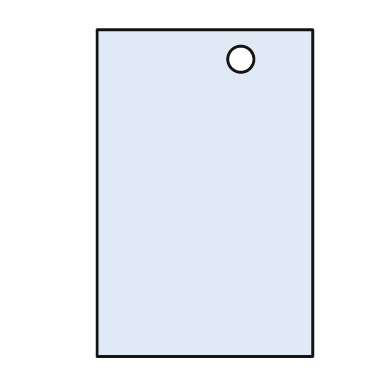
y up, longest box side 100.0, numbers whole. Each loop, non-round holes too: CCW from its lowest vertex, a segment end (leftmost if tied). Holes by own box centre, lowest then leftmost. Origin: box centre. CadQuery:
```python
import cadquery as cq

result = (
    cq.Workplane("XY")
    .moveTo(-33.0, -50.0)
    .lineTo(33.0, -50.0)
    .lineTo(33.0, 50.0)
    .lineTo(-33.0, 50.0)
    .close()
    .moveTo(11.0, 41.0)
    .circle(4.0)
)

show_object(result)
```